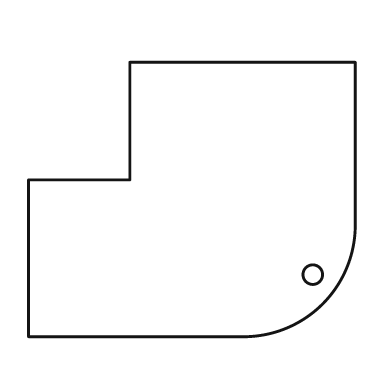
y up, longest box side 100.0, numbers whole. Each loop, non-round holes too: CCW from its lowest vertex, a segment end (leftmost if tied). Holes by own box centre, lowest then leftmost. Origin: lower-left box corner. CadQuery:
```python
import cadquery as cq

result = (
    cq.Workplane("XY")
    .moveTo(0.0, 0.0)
    .lineTo(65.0, 0.0)
    .threePointArc((90.0, 10.0), (100.0, 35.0))
    .lineTo(100.0, 84.0)
    .lineTo(31.0, 84.0)
    .lineTo(31.0, 48.0)
    .lineTo(0.0, 48.0)
    .close()
    .moveTo(87.0, 19.0)
    .circle(3.0)
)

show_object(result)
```